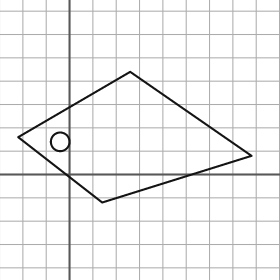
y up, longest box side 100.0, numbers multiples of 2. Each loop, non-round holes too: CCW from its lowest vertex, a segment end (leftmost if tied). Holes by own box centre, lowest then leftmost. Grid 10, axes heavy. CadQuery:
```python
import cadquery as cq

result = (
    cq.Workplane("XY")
    .moveTo(14.0, -12.0)
    .lineTo(78.0, 8.0)
    .lineTo(26.0, 44.0)
    .lineTo(-22.0, 16.0)
    .close()
    .moveTo(-4.0, 14.0)
    .circle(4.0)
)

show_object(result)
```